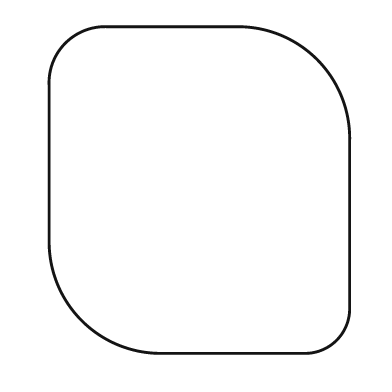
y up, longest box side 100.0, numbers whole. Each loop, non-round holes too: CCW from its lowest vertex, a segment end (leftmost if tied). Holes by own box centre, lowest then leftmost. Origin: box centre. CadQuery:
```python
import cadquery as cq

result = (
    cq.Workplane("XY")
    .moveTo(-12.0, -50.0)
    .lineTo(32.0, -50.0)
    .threePointArc((42.0, -46.0), (46.0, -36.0))
    .lineTo(46.0, 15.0)
    .threePointArc((36.0, 40.0), (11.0, 50.0))
    .lineTo(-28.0, 50.0)
    .threePointArc((-41.0, 45.0), (-46.0, 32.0))
    .lineTo(-46.0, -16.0)
    .threePointArc((-36.0, -40.0), (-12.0, -50.0))
    .close()
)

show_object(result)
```